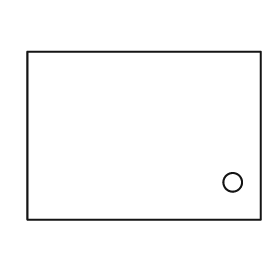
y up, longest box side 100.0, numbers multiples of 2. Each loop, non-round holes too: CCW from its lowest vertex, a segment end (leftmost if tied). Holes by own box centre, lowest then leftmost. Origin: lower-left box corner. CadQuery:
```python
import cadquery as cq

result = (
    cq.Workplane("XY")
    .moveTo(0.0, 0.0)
    .lineTo(100.0, 0.0)
    .lineTo(100.0, 72.0)
    .lineTo(0.0, 72.0)
    .close()
    .moveTo(88.0, 16.0)
    .circle(4.0)
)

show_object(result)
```